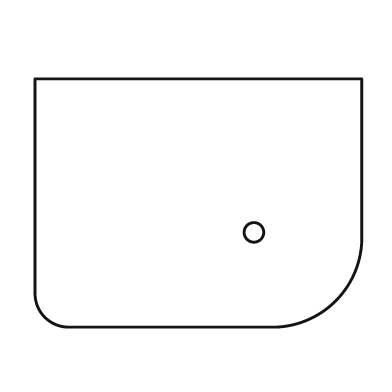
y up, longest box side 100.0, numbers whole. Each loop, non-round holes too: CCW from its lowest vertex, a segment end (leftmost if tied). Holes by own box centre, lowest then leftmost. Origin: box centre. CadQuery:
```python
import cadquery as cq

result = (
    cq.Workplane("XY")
    .moveTo(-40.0, -38.0)
    .lineTo(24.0, -38.0)
    .threePointArc((42.0, -30.0), (50.0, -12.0))
    .lineTo(50.0, 38.0)
    .lineTo(-50.0, 38.0)
    .lineTo(-50.0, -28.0)
    .threePointArc((-47.0, -35.0), (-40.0, -38.0))
    .close()
    .moveTo(17.0, -9.0)
    .circle(3.0)
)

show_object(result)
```